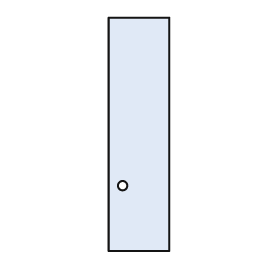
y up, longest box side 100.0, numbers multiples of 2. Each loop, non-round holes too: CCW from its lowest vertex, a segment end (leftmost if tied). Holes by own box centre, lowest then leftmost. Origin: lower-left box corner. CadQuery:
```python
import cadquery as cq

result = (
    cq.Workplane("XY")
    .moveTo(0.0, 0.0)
    .lineTo(26.0, 0.0)
    .lineTo(26.0, 100.0)
    .lineTo(0.0, 100.0)
    .close()
    .moveTo(6.0, 28.0)
    .circle(2.0)
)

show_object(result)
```